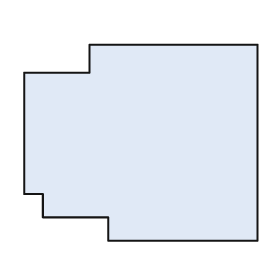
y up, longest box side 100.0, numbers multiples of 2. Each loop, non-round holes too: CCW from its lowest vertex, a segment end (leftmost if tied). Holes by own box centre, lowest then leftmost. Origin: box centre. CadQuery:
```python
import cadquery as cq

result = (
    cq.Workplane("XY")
    .moveTo(-14.0, -42.0)
    .lineTo(50.0, -42.0)
    .lineTo(50.0, 42.0)
    .lineTo(-22.0, 42.0)
    .lineTo(-22.0, 30.0)
    .lineTo(-50.0, 30.0)
    .lineTo(-50.0, -22.0)
    .lineTo(-42.0, -22.0)
    .lineTo(-42.0, -32.0)
    .lineTo(-14.0, -32.0)
    .close()
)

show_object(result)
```